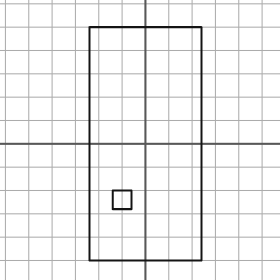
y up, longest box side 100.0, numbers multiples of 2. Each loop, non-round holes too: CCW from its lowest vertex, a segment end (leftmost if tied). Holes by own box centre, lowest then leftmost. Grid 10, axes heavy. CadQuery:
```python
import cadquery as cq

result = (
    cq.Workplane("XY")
    .moveTo(-24.0, -50.0)
    .lineTo(24.0, -50.0)
    .lineTo(24.0, 50.0)
    .lineTo(-24.0, 50.0)
    .close()
    .moveTo(-14.0, -28.0)
    .lineTo(-6.0, -28.0)
    .lineTo(-6.0, -20.0)
    .lineTo(-14.0, -20.0)
    .close()
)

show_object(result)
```